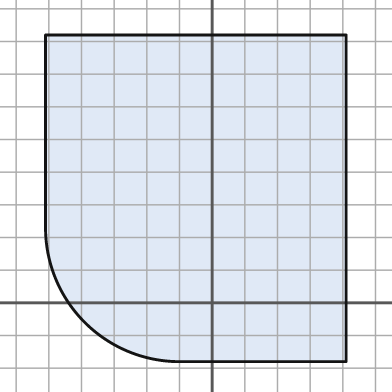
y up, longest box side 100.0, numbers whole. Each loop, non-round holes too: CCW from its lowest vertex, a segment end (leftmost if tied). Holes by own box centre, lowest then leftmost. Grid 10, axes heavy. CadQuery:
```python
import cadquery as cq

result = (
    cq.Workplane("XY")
    .moveTo(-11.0, -18.0)
    .lineTo(41.0, -18.0)
    .lineTo(41.0, 82.0)
    .lineTo(-51.0, 82.0)
    .lineTo(-51.0, 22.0)
    .threePointArc((-39.0, -6.0), (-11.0, -18.0))
    .close()
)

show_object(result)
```